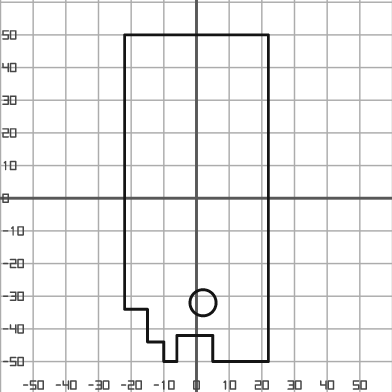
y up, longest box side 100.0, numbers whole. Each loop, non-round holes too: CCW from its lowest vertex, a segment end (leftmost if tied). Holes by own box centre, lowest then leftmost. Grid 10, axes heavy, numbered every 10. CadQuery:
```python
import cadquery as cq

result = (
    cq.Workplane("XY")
    .moveTo(-10.0, -50.0)
    .lineTo(-6.0, -50.0)
    .lineTo(-6.0, -42.0)
    .lineTo(5.0, -42.0)
    .lineTo(5.0, -50.0)
    .lineTo(22.0, -50.0)
    .lineTo(22.0, 50.0)
    .lineTo(-22.0, 50.0)
    .lineTo(-22.0, -34.0)
    .lineTo(-15.0, -34.0)
    .lineTo(-15.0, -44.0)
    .lineTo(-10.0, -44.0)
    .close()
    .moveTo(2.0, -32.0)
    .circle(4.0)
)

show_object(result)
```